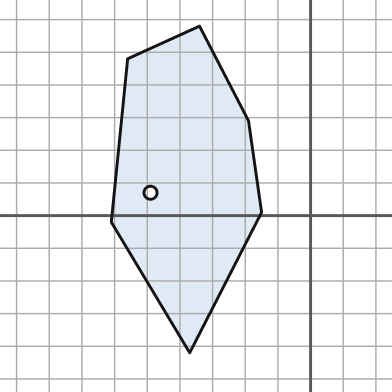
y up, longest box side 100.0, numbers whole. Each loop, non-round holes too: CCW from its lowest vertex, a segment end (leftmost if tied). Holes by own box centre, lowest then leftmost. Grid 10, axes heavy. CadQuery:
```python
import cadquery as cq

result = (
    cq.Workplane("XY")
    .moveTo(-37.0, -42.0)
    .lineTo(-15.0, 1.0)
    .lineTo(-19.0, 29.0)
    .lineTo(-34.0, 58.0)
    .lineTo(-56.0, 48.0)
    .lineTo(-61.0, -2.0)
    .close()
    .moveTo(-49.0, 7.0)
    .circle(2.0)
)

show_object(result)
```